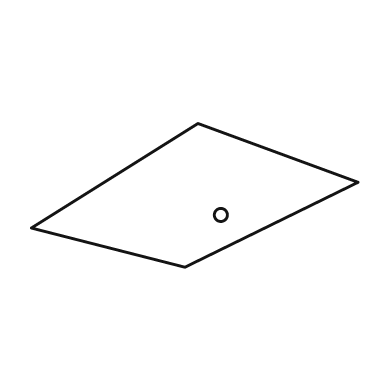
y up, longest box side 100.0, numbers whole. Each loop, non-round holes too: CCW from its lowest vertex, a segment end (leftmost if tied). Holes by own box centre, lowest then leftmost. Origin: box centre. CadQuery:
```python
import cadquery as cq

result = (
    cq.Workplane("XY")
    .moveTo(-3.0, -22.0)
    .lineTo(50.0, 4.0)
    .lineTo(1.0, 22.0)
    .lineTo(-50.0, -10.0)
    .close()
    .moveTo(8.0, -6.0)
    .circle(2.0)
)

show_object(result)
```